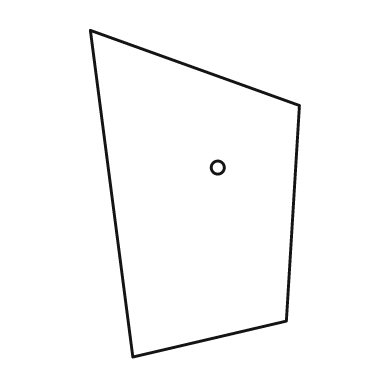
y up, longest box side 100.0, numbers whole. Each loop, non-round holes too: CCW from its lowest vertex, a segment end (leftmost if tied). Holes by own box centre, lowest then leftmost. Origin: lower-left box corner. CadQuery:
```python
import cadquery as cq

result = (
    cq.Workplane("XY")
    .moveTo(13.0, 0.0)
    .lineTo(60.0, 11.0)
    .lineTo(64.0, 77.0)
    .lineTo(0.0, 100.0)
    .close()
    .moveTo(39.0, 58.0)
    .circle(2.0)
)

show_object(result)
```